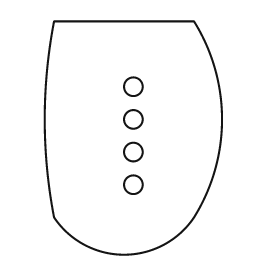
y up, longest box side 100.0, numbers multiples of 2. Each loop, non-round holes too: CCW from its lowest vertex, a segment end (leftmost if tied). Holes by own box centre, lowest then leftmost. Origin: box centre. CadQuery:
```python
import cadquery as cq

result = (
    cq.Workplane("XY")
    .moveTo(-34.0, -34.0)
    .threePointArc((-4.0, -50.0), (26.0, -34.0))
    .threePointArc((38.0, 8.0), (26.0, 50.0))
    .lineTo(-34.0, 50.0)
    .threePointArc((-38.0, 8.0), (-34.0, -34.0))
    .close()
    .moveTo(0.0, -20.0)
    .circle(4.0)
    .moveTo(0.0, -6.0)
    .circle(4.0)
    .moveTo(0.0, 8.0)
    .circle(4.0)
    .moveTo(0.0, 22.0)
    .circle(4.0)
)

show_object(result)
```